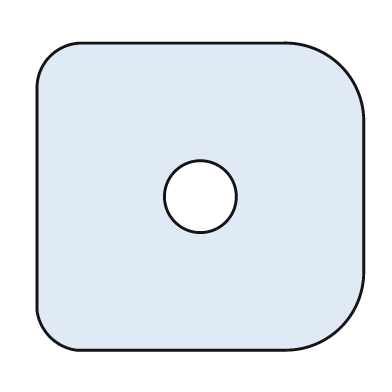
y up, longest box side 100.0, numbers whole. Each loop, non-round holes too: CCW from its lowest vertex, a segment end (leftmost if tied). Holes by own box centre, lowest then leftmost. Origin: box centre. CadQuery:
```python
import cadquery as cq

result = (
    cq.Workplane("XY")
    .moveTo(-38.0, -47.0)
    .lineTo(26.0, -47.0)
    .threePointArc((43.0, -40.0), (50.0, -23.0))
    .lineTo(50.0, 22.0)
    .threePointArc((43.0, 40.0), (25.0, 47.0))
    .lineTo(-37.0, 47.0)
    .threePointArc((-46.0, 43.0), (-50.0, 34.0))
    .lineTo(-50.0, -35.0)
    .threePointArc((-46.0, -43.0), (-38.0, -47.0))
    .close()
    .moveTo(0.0, 0.0)
    .circle(11.0)
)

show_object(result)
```